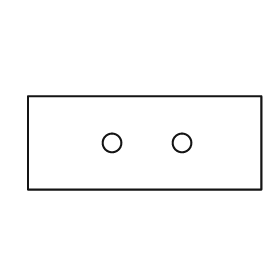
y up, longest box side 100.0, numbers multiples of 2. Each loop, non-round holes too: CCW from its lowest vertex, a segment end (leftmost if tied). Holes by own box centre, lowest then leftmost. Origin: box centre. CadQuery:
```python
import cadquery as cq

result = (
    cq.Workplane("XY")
    .moveTo(-50.0, -20.0)
    .lineTo(50.0, -20.0)
    .lineTo(50.0, 20.0)
    .lineTo(-50.0, 20.0)
    .close()
    .moveTo(-14.0, 0.0)
    .circle(4.0)
    .moveTo(16.0, 0.0)
    .circle(4.0)
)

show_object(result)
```